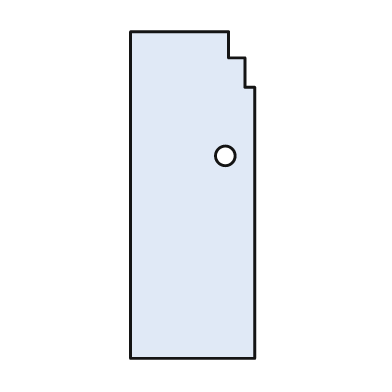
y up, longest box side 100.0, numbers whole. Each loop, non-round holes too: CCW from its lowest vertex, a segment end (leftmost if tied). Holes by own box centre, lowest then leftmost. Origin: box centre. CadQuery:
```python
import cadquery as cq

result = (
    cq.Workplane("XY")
    .moveTo(-19.0, -50.0)
    .lineTo(19.0, -50.0)
    .lineTo(19.0, 33.0)
    .lineTo(16.0, 33.0)
    .lineTo(16.0, 42.0)
    .lineTo(11.0, 42.0)
    .lineTo(11.0, 50.0)
    .lineTo(-19.0, 50.0)
    .close()
    .moveTo(10.0, 12.0)
    .circle(3.0)
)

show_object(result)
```